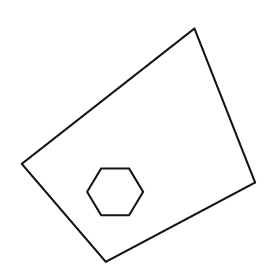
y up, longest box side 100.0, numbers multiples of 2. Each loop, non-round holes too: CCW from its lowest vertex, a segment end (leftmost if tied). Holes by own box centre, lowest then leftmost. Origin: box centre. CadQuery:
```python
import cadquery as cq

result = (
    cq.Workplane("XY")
    .moveTo(-14.0, -50.0)
    .lineTo(50.0, -16.0)
    .lineTo(24.0, 50.0)
    .lineTo(-50.0, -8.0)
    .close()
    .moveTo(-16.0, -30.0)
    .lineTo(-4.0, -30.0)
    .lineTo(2.0, -20.0)
    .lineTo(-4.0, -10.0)
    .lineTo(-16.0, -10.0)
    .lineTo(-22.0, -20.0)
    .close()
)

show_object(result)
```